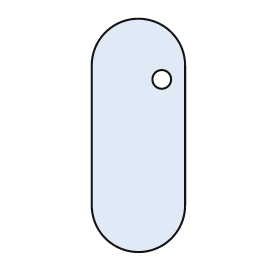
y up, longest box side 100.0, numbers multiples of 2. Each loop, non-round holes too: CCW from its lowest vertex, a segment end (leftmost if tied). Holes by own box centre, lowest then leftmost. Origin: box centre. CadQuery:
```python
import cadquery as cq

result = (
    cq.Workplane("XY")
    .moveTo(-20.0, -30.0)
    .threePointArc((0.0, -50.0), (20.0, -30.0))
    .lineTo(20.0, 30.0)
    .threePointArc((0.0, 50.0), (-20.0, 30.0))
    .close()
    .moveTo(10.0, 24.0)
    .circle(4.0)
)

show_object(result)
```